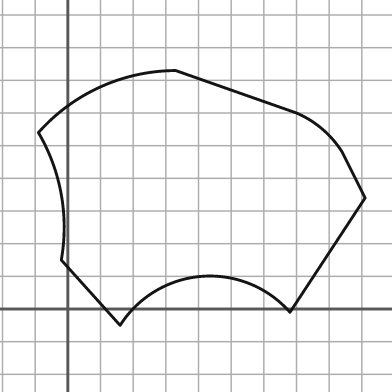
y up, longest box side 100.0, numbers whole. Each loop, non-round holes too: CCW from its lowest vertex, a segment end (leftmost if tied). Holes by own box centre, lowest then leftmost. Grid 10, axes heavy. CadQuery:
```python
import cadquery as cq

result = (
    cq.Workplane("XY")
    .moveTo(16.0, -5.0)
    .threePointArc((41.0, 10.0), (68.0, -1.0))
    .lineTo(91.0, 34.0)
    .lineTo(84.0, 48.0)
    .threePointArc((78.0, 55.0), (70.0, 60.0))
    .lineTo(33.0, 73.0)
    .threePointArc((10.0, 68.0), (-9.0, 54.0))
    .threePointArc((-2.0, 35.0), (-2.0, 15.0))
    .close()
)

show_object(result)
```